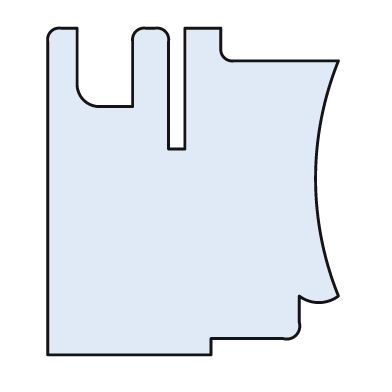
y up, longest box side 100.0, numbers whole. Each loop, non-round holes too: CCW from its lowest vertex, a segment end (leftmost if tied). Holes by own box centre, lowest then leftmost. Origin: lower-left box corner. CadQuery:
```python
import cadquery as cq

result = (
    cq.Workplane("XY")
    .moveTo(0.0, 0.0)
    .lineTo(50.0, 0.0)
    .lineTo(50.0, 5.0)
    .lineTo(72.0, 5.0)
    .threePointArc((76.0, 6.0), (77.0, 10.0))
    .lineTo(77.0, 18.0)
    .threePointArc((83.0, 16.0), (89.0, 18.0))
    .threePointArc((82.0, 54.0), (89.0, 90.0))
    .lineTo(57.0, 90.0)
    .threePointArc((54.0, 91.0), (53.0, 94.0))
    .lineTo(53.0, 100.0)
    .lineTo(42.0, 100.0)
    .lineTo(42.0, 63.0)
    .lineTo(37.0, 63.0)
    .lineTo(37.0, 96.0)
    .threePointArc((36.0, 99.0), (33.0, 100.0))
    .lineTo(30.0, 100.0)
    .threePointArc((27.0, 99.0), (26.0, 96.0))
    .lineTo(26.0, 76.0)
    .lineTo(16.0, 76.0)
    .threePointArc((11.0, 78.0), (9.0, 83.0))
    .lineTo(9.0, 100.0)
    .lineTo(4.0, 100.0)
    .threePointArc((1.0, 99.0), (0.0, 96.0))
    .close()
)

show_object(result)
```